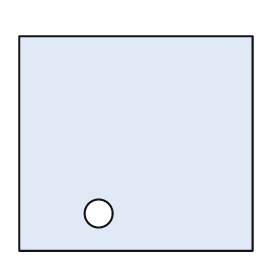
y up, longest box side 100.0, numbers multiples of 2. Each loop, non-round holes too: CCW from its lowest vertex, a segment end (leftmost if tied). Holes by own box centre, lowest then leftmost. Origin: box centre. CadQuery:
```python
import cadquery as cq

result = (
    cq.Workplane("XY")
    .moveTo(-50.0, -46.0)
    .lineTo(50.0, -46.0)
    .lineTo(50.0, 46.0)
    .lineTo(-50.0, 46.0)
    .close()
    .moveTo(-16.0, -30.0)
    .circle(6.0)
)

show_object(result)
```